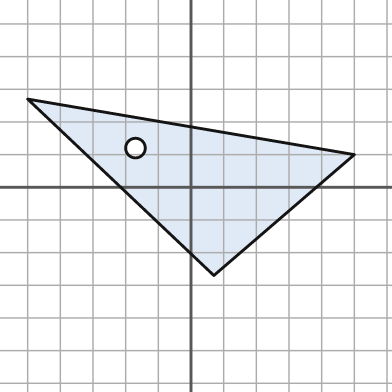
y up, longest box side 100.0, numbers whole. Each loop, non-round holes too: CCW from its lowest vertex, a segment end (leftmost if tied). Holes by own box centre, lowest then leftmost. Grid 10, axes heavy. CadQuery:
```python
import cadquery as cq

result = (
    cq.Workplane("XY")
    .moveTo(7.0, -27.0)
    .lineTo(50.0, 10.0)
    .lineTo(-50.0, 27.0)
    .close()
    .moveTo(-17.0, 12.0)
    .circle(3.0)
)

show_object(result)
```